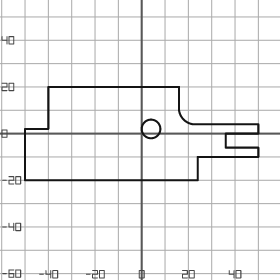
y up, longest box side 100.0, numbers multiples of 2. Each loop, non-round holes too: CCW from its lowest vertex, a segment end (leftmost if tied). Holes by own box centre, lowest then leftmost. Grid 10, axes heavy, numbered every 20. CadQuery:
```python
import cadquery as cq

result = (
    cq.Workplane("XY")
    .moveTo(-50.0, -20.0)
    .lineTo(24.0, -20.0)
    .lineTo(24.0, -10.0)
    .lineTo(50.0, -10.0)
    .lineTo(50.0, -6.0)
    .lineTo(36.0, -6.0)
    .lineTo(36.0, 0.0)
    .lineTo(50.0, 0.0)
    .lineTo(50.0, 4.0)
    .lineTo(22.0, 4.0)
    .threePointArc((18.0, 6.0), (16.0, 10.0))
    .lineTo(16.0, 20.0)
    .lineTo(-40.0, 20.0)
    .lineTo(-40.0, 2.0)
    .lineTo(-50.0, 2.0)
    .close()
    .moveTo(4.0, 2.0)
    .circle(4.0)
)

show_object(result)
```